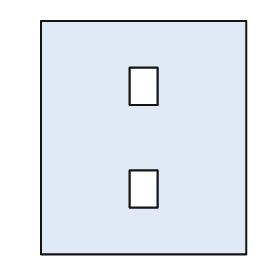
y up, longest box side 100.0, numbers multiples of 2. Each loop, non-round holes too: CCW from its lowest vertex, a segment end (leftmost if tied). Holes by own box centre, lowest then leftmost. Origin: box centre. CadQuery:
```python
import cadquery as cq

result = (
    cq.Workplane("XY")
    .moveTo(-44.0, -50.0)
    .lineTo(44.0, -50.0)
    .lineTo(44.0, 50.0)
    .lineTo(-44.0, 50.0)
    .close()
    .moveTo(-6.0, -30.0)
    .lineTo(6.0, -30.0)
    .lineTo(6.0, -14.0)
    .lineTo(-6.0, -14.0)
    .close()
    .moveTo(-6.0, 14.0)
    .lineTo(6.0, 14.0)
    .lineTo(6.0, 30.0)
    .lineTo(-6.0, 30.0)
    .close()
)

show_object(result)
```